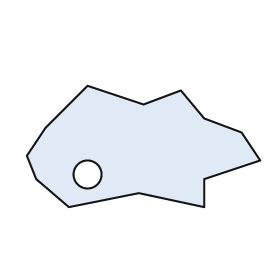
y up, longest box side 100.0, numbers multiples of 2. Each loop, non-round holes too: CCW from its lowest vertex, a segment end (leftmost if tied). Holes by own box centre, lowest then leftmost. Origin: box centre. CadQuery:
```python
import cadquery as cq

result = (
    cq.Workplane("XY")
    .moveTo(-32.0, -26.0)
    .lineTo(-2.0, -20.0)
    .lineTo(26.0, -26.0)
    .lineTo(26.0, -14.0)
    .lineTo(50.0, -6.0)
    .lineTo(42.0, 6.0)
    .lineTo(26.0, 12.0)
    .lineTo(16.0, 24.0)
    .lineTo(0.0, 18.0)
    .lineTo(-24.0, 26.0)
    .lineTo(-42.0, 8.0)
    .lineTo(-50.0, -4.0)
    .lineTo(-46.0, -14.0)
    .close()
    .moveTo(-24.0, -12.0)
    .circle(6.0)
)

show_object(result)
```